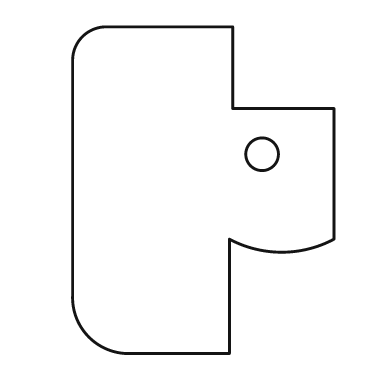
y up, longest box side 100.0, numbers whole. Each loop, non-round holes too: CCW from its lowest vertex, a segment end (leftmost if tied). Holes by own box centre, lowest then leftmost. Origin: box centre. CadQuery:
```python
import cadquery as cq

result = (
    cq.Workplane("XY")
    .moveTo(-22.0, -50.0)
    .lineTo(8.0, -50.0)
    .lineTo(8.0, -15.0)
    .threePointArc((24.0, -19.0), (40.0, -15.0))
    .lineTo(40.0, 25.0)
    .lineTo(9.0, 25.0)
    .lineTo(9.0, 50.0)
    .lineTo(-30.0, 50.0)
    .threePointArc((-37.0, 47.0), (-40.0, 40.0))
    .lineTo(-40.0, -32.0)
    .threePointArc((-35.0, -45.0), (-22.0, -50.0))
    .close()
    .moveTo(18.0, 11.0)
    .circle(5.0)
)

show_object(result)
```